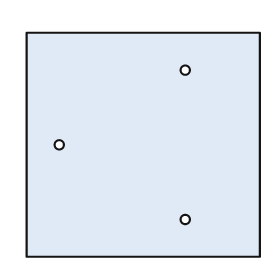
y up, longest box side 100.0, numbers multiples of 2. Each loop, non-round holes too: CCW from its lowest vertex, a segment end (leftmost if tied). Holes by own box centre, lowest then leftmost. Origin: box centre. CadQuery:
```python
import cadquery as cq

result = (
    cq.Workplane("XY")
    .moveTo(-50.0, -48.0)
    .lineTo(50.0, -48.0)
    .lineTo(50.0, 48.0)
    .lineTo(-50.0, 48.0)
    .close()
    .moveTo(18.0, -32.0)
    .circle(2.0)
    .moveTo(-36.0, 0.0)
    .circle(2.0)
    .moveTo(18.0, 32.0)
    .circle(2.0)
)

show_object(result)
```